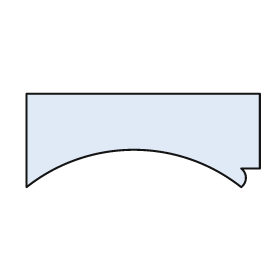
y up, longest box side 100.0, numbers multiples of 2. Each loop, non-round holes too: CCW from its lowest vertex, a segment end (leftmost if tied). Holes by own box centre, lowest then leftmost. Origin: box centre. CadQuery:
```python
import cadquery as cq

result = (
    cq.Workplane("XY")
    .moveTo(-50.0, -20.0)
    .threePointArc((-4.0, -4.0), (42.0, -20.0))
    .threePointArc((44.0, -16.0), (42.0, -12.0))
    .lineTo(50.0, -12.0)
    .lineTo(50.0, 20.0)
    .lineTo(-50.0, 20.0)
    .close()
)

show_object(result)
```